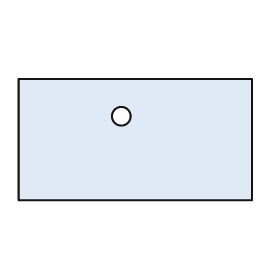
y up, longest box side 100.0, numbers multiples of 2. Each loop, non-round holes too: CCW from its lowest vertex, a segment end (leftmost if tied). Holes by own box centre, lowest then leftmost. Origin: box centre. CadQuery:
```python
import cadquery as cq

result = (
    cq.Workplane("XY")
    .moveTo(-50.0, -26.0)
    .lineTo(50.0, -26.0)
    .lineTo(50.0, 26.0)
    .lineTo(-50.0, 26.0)
    .close()
    .moveTo(-6.0, 10.0)
    .circle(4.0)
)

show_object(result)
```